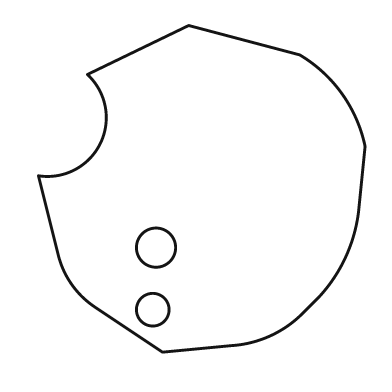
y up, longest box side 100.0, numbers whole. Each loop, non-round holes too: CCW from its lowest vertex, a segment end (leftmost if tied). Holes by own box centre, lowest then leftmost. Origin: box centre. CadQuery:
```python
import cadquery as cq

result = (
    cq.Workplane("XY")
    .moveTo(-12.0, -50.0)
    .lineTo(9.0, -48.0)
    .threePointArc((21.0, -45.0), (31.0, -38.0))
    .lineTo(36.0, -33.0)
    .threePointArc((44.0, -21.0), (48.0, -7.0))
    .lineTo(50.0, 13.0)
    .threePointArc((43.0, 29.0), (30.0, 41.0))
    .lineTo(-4.0, 50.0)
    .lineTo(-35.0, 35.0)
    .threePointArc((-31.0, 14.0), (-50.0, 4.0))
    .lineTo(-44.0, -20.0)
    .threePointArc((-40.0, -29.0), (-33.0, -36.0))
    .close()
    .moveTo(-15.0, -37.0)
    .circle(5.0)
    .moveTo(-14.0, -18.0)
    .circle(6.0)
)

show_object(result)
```